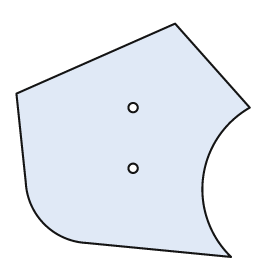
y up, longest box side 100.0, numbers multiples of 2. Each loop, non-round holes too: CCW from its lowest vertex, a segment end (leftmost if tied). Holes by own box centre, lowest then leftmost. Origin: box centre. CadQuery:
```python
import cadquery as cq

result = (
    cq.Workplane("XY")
    .moveTo(42.0, -50.0)
    .threePointArc((30.0, -16.0), (50.0, 14.0))
    .lineTo(18.0, 50.0)
    .lineTo(-50.0, 20.0)
    .lineTo(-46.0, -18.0)
    .threePointArc((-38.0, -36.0), (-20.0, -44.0))
    .close()
    .moveTo(0.0, -12.0)
    .circle(2.0)
    .moveTo(0.0, 14.0)
    .circle(2.0)
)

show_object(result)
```